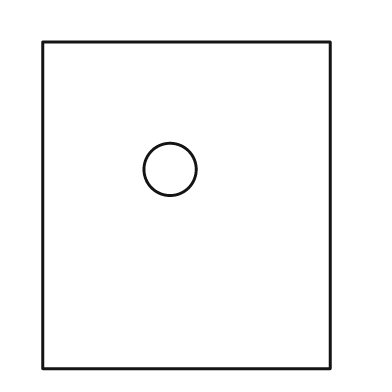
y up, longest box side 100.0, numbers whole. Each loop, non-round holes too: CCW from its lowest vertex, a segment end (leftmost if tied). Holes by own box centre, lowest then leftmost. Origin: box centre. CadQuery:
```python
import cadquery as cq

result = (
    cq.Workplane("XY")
    .moveTo(-44.0, -50.0)
    .lineTo(44.0, -50.0)
    .lineTo(44.0, 50.0)
    .lineTo(-44.0, 50.0)
    .close()
    .moveTo(-5.0, 11.0)
    .circle(8.0)
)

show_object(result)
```